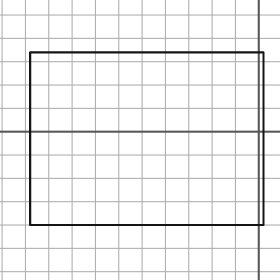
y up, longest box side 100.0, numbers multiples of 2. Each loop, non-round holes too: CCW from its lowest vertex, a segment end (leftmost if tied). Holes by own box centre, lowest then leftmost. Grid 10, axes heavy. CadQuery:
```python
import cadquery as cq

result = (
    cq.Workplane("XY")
    .moveTo(-98.0, -40.0)
    .lineTo(2.0, -40.0)
    .lineTo(2.0, 34.0)
    .lineTo(-98.0, 34.0)
    .close()
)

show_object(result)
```